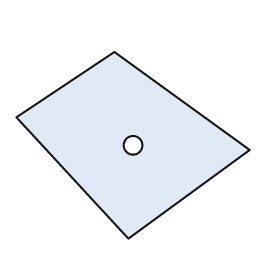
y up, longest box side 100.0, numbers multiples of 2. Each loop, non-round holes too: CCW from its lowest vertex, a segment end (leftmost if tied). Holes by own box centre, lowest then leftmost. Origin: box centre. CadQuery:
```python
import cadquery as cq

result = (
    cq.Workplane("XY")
    .moveTo(-2.0, -40.0)
    .lineTo(50.0, -2.0)
    .lineTo(-8.0, 40.0)
    .lineTo(-50.0, 12.0)
    .close()
    .moveTo(0.0, 0.0)
    .circle(4.0)
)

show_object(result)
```